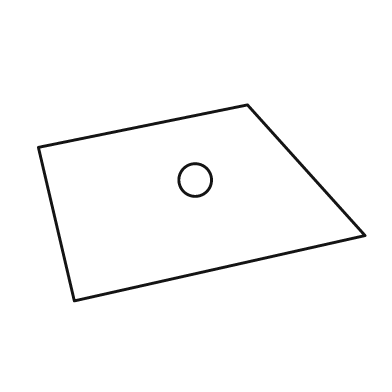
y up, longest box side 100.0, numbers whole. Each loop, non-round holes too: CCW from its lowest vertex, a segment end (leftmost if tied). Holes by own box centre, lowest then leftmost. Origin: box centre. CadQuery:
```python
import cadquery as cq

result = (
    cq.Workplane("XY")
    .moveTo(-39.0, -30.0)
    .lineTo(50.0, -10.0)
    .lineTo(14.0, 30.0)
    .lineTo(-50.0, 17.0)
    .close()
    .moveTo(-2.0, 7.0)
    .circle(5.0)
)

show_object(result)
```